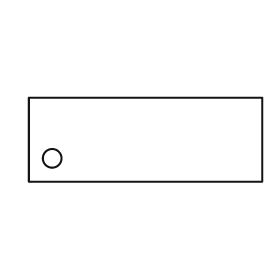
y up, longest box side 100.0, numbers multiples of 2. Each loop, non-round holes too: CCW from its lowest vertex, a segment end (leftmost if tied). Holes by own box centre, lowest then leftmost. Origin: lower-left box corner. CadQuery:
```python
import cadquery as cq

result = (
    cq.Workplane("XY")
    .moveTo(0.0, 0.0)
    .lineTo(100.0, 0.0)
    .lineTo(100.0, 36.0)
    .lineTo(0.0, 36.0)
    .close()
    .moveTo(10.0, 10.0)
    .circle(4.0)
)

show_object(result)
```